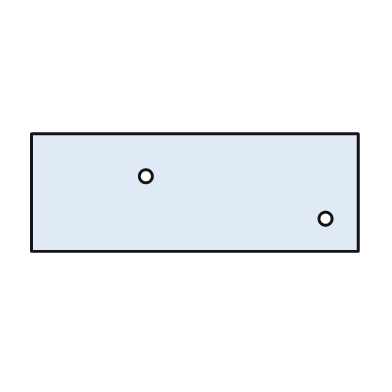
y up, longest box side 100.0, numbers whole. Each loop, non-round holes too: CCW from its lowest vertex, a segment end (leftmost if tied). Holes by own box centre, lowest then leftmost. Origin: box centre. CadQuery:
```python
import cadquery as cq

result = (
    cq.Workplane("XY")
    .moveTo(-50.0, -18.0)
    .lineTo(50.0, -18.0)
    .lineTo(50.0, 18.0)
    .lineTo(-50.0, 18.0)
    .close()
    .moveTo(40.0, -8.0)
    .circle(2.0)
    .moveTo(-15.0, 5.0)
    .circle(2.0)
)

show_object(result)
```